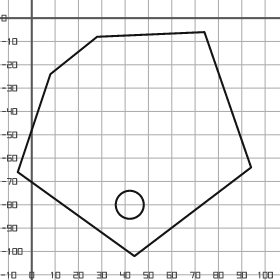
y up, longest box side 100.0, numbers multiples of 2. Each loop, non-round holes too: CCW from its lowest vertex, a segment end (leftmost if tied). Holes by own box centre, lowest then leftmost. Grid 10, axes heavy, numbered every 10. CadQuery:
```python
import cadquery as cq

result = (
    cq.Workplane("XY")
    .moveTo(44.0, -102.0)
    .lineTo(94.0, -64.0)
    .lineTo(74.0, -6.0)
    .lineTo(28.0, -8.0)
    .lineTo(8.0, -24.0)
    .lineTo(-6.0, -66.0)
    .close()
    .moveTo(42.0, -80.0)
    .circle(6.0)
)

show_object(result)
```